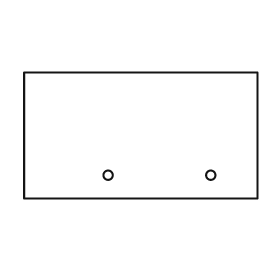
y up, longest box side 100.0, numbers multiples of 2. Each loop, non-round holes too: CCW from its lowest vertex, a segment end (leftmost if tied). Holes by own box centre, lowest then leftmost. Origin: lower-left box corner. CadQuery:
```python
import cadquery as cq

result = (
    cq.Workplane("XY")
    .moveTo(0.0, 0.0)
    .lineTo(100.0, 0.0)
    .lineTo(100.0, 54.0)
    .lineTo(0.0, 54.0)
    .close()
    .moveTo(36.0, 10.0)
    .circle(2.0)
    .moveTo(80.0, 10.0)
    .circle(2.0)
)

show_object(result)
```